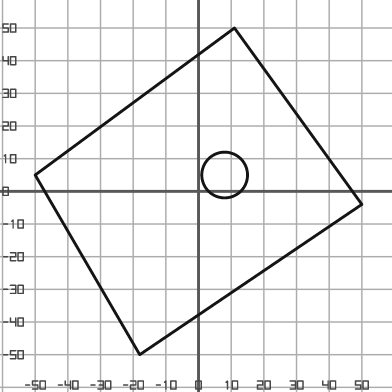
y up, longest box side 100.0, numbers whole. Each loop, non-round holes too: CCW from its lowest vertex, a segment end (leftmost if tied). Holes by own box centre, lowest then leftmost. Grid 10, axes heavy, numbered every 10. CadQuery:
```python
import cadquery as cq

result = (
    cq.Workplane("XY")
    .moveTo(-18.0, -50.0)
    .lineTo(50.0, -4.0)
    .lineTo(11.0, 50.0)
    .lineTo(-50.0, 5.0)
    .close()
    .moveTo(8.0, 5.0)
    .circle(7.0)
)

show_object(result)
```